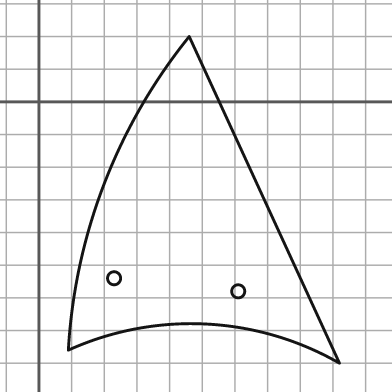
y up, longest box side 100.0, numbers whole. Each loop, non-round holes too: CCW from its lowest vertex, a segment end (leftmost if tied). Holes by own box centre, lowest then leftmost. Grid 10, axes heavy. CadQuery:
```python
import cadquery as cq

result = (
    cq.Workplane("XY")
    .moveTo(92.0, -80.0)
    .lineTo(46.0, 20.0)
    .threePointArc((20.0, -25.0), (9.0, -76.0))
    .threePointArc((51.0, -68.0), (92.0, -80.0))
    .close()
    .moveTo(61.0, -58.0)
    .circle(2.0)
    .moveTo(23.0, -54.0)
    .circle(2.0)
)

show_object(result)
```